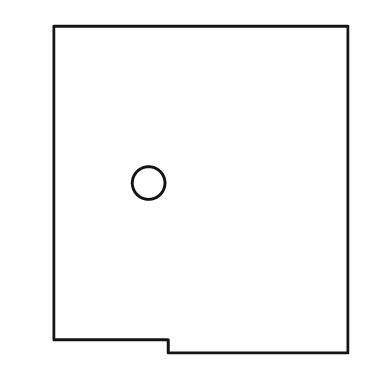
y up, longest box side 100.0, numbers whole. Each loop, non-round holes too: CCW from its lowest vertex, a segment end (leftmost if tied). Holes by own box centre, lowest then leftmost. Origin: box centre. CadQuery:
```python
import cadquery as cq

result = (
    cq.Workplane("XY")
    .moveTo(-10.0, -50.0)
    .lineTo(45.0, -50.0)
    .lineTo(45.0, 50.0)
    .lineTo(-45.0, 50.0)
    .lineTo(-45.0, -46.0)
    .lineTo(-10.0, -46.0)
    .close()
    .moveTo(-16.0, 2.0)
    .circle(5.0)
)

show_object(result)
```